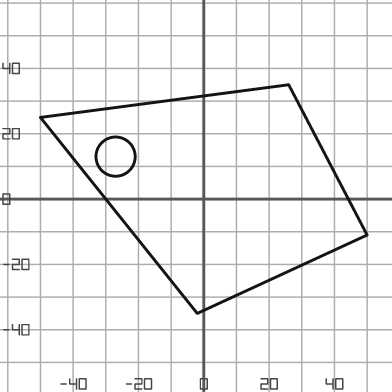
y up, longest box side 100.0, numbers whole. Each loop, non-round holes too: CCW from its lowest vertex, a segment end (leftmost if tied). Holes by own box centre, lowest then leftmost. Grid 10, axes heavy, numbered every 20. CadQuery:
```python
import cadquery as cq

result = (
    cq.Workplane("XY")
    .moveTo(-2.0, -35.0)
    .lineTo(50.0, -11.0)
    .lineTo(26.0, 35.0)
    .lineTo(-50.0, 25.0)
    .close()
    .moveTo(-27.0, 13.0)
    .circle(6.0)
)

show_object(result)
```